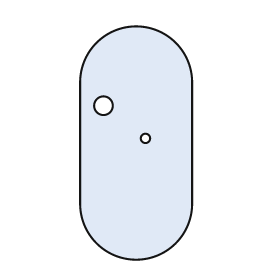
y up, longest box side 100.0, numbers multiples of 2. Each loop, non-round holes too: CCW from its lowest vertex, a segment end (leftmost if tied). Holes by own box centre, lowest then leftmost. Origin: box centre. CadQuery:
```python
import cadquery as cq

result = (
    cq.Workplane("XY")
    .moveTo(-24.0, -26.0)
    .threePointArc((0.0, -50.0), (24.0, -26.0))
    .lineTo(24.0, 26.0)
    .threePointArc((0.0, 50.0), (-24.0, 26.0))
    .close()
    .moveTo(4.0, 2.0)
    .circle(2.0)
    .moveTo(-14.0, 16.0)
    .circle(4.0)
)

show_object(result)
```